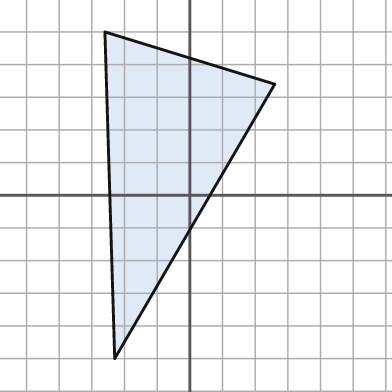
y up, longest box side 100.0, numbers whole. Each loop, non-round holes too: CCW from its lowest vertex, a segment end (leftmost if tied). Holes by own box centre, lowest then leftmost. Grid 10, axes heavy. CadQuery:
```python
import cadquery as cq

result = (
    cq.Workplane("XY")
    .moveTo(-23.0, -50.0)
    .lineTo(26.0, 34.0)
    .lineTo(-26.0, 50.0)
    .close()
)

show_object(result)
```